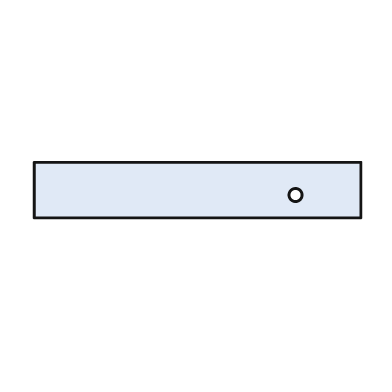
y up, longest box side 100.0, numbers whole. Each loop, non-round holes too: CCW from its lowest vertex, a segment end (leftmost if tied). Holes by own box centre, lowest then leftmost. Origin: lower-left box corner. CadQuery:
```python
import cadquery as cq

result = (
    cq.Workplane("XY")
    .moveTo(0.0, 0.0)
    .lineTo(100.0, 0.0)
    .lineTo(100.0, 17.0)
    .lineTo(0.0, 17.0)
    .close()
    .moveTo(80.0, 7.0)
    .circle(2.0)
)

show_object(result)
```